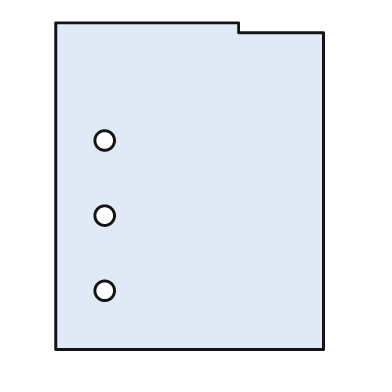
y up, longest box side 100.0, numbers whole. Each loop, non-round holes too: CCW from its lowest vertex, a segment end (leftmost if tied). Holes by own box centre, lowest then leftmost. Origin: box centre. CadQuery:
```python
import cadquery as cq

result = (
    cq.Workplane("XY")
    .moveTo(-41.0, -50.0)
    .lineTo(41.0, -50.0)
    .lineTo(41.0, 47.0)
    .lineTo(15.0, 47.0)
    .lineTo(15.0, 50.0)
    .lineTo(-41.0, 50.0)
    .close()
    .moveTo(-26.0, -32.0)
    .circle(3.0)
    .moveTo(-26.0, -9.0)
    .circle(3.0)
    .moveTo(-26.0, 14.0)
    .circle(3.0)
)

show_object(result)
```